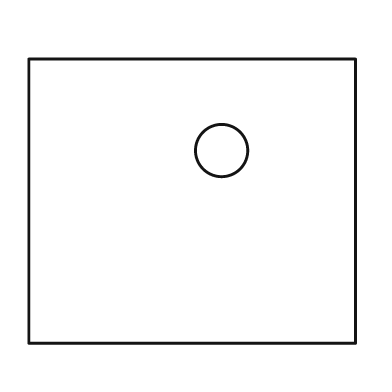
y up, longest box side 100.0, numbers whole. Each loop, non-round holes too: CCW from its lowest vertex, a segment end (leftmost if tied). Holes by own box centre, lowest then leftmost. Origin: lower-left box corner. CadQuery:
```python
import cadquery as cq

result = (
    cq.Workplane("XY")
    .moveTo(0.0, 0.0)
    .lineTo(100.0, 0.0)
    .lineTo(100.0, 87.0)
    .lineTo(0.0, 87.0)
    .close()
    .moveTo(59.0, 59.0)
    .circle(8.0)
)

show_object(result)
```